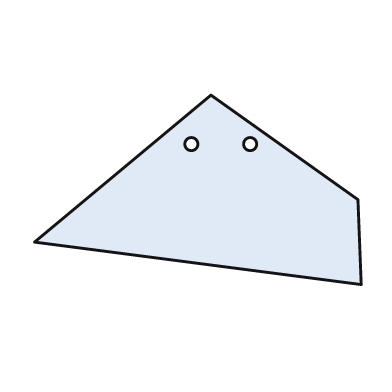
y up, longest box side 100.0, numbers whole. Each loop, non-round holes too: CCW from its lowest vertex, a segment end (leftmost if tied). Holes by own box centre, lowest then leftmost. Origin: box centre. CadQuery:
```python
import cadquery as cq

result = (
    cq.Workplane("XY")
    .moveTo(50.0, -29.0)
    .lineTo(49.0, -3.0)
    .lineTo(4.0, 29.0)
    .lineTo(-50.0, -16.0)
    .close()
    .moveTo(-2.0, 14.0)
    .circle(2.0)
    .moveTo(16.0, 14.0)
    .circle(2.0)
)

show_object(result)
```